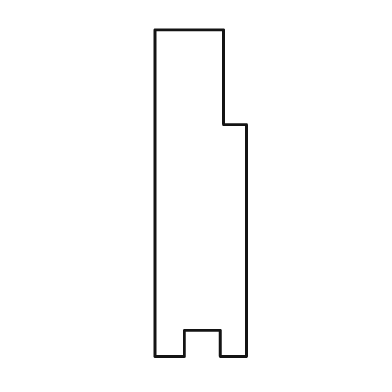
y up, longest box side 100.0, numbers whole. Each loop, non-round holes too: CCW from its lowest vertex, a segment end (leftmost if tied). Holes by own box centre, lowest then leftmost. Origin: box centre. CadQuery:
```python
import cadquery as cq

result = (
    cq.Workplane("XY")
    .moveTo(-14.0, -50.0)
    .lineTo(-5.0, -50.0)
    .lineTo(-5.0, -42.0)
    .lineTo(6.0, -42.0)
    .lineTo(6.0, -50.0)
    .lineTo(14.0, -50.0)
    .lineTo(14.0, 21.0)
    .lineTo(7.0, 21.0)
    .lineTo(7.0, 50.0)
    .lineTo(-14.0, 50.0)
    .close()
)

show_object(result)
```